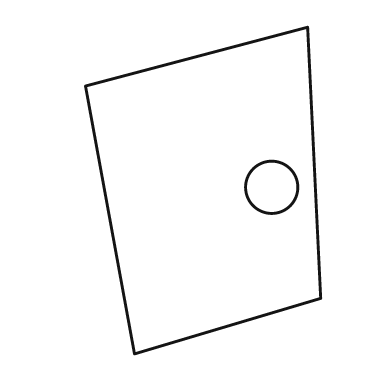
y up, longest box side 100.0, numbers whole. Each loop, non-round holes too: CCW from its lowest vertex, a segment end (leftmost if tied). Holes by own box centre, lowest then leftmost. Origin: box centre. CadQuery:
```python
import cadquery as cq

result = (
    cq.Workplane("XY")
    .moveTo(-21.0, -50.0)
    .lineTo(36.0, -33.0)
    .lineTo(32.0, 50.0)
    .lineTo(-36.0, 32.0)
    .close()
    .moveTo(21.0, 1.0)
    .circle(8.0)
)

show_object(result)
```